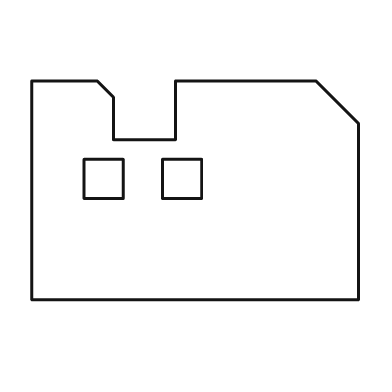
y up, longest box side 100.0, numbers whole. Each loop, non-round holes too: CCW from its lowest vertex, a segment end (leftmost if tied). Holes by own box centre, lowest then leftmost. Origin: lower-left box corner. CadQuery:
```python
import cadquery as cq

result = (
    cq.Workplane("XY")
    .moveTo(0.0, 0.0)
    .lineTo(100.0, 0.0)
    .lineTo(100.0, 54.0)
    .lineTo(87.0, 67.0)
    .lineTo(44.0, 67.0)
    .lineTo(44.0, 49.0)
    .lineTo(25.0, 49.0)
    .lineTo(25.0, 62.0)
    .lineTo(20.0, 67.0)
    .lineTo(0.0, 67.0)
    .close()
    .moveTo(16.0, 31.0)
    .lineTo(28.0, 31.0)
    .lineTo(28.0, 43.0)
    .lineTo(16.0, 43.0)
    .close()
    .moveTo(40.0, 31.0)
    .lineTo(52.0, 31.0)
    .lineTo(52.0, 43.0)
    .lineTo(40.0, 43.0)
    .close()
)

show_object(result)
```